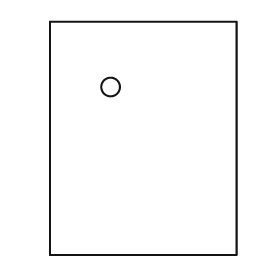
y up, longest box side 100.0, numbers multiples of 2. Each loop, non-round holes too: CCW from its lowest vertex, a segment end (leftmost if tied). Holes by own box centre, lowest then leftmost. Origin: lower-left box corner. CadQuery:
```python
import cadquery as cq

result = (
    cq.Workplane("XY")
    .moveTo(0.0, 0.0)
    .lineTo(80.0, 0.0)
    .lineTo(80.0, 100.0)
    .lineTo(0.0, 100.0)
    .close()
    .moveTo(26.0, 72.0)
    .circle(4.0)
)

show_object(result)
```